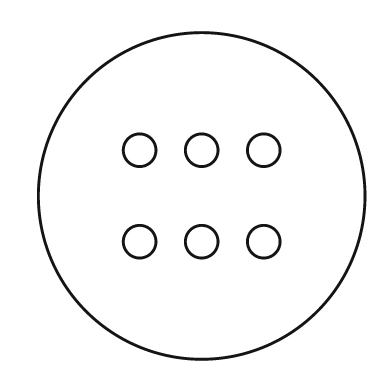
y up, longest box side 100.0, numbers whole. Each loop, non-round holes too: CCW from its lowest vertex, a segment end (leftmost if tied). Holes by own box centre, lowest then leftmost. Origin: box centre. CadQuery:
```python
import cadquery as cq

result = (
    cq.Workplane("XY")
    .moveTo(0.0, 0.0)
    .circle(50.0)
    .moveTo(-19.0, -14.0)
    .circle(5.0)
    .moveTo(0.0, -14.0)
    .circle(5.0)
    .moveTo(19.0, -14.0)
    .circle(5.0)
    .moveTo(-19.0, 14.0)
    .circle(5.0)
    .moveTo(0.0, 14.0)
    .circle(5.0)
    .moveTo(19.0, 14.0)
    .circle(5.0)
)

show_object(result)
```